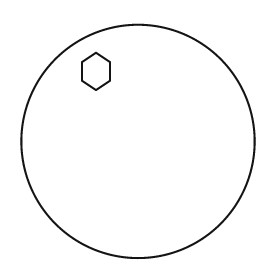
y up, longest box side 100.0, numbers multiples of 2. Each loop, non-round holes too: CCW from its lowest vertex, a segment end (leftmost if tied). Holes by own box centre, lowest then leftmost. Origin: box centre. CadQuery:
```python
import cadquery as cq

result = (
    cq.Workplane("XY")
    .moveTo(0.0, 0.0)
    .circle(50.0)
    .moveTo(-18.0, 22.0)
    .lineTo(-12.0, 26.0)
    .lineTo(-12.0, 34.0)
    .lineTo(-18.0, 38.0)
    .lineTo(-24.0, 34.0)
    .lineTo(-24.0, 26.0)
    .close()
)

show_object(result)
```